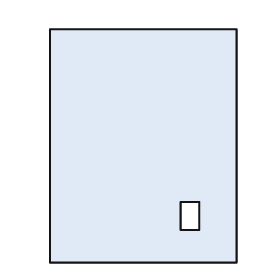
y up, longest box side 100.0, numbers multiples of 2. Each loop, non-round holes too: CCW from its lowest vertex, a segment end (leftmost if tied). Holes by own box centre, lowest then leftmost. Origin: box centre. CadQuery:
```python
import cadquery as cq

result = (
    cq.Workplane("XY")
    .moveTo(-40.0, -50.0)
    .lineTo(40.0, -50.0)
    .lineTo(40.0, 50.0)
    .lineTo(-40.0, 50.0)
    .close()
    .moveTo(16.0, -36.0)
    .lineTo(24.0, -36.0)
    .lineTo(24.0, -24.0)
    .lineTo(16.0, -24.0)
    .close()
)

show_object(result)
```